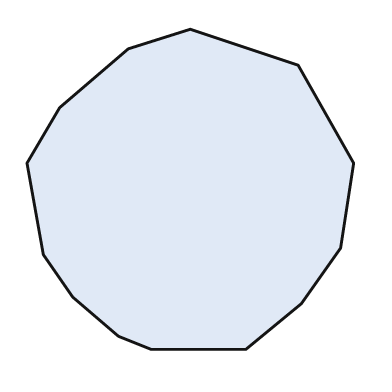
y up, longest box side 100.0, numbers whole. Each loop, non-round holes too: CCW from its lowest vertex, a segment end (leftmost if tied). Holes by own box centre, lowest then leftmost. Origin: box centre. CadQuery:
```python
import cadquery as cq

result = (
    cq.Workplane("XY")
    .moveTo(-12.0, -49.0)
    .lineTo(17.0, -49.0)
    .lineTo(34.0, -35.0)
    .lineTo(46.0, -18.0)
    .lineTo(50.0, 8.0)
    .lineTo(33.0, 38.0)
    .lineTo(0.0, 49.0)
    .lineTo(-19.0, 43.0)
    .lineTo(-40.0, 25.0)
    .lineTo(-50.0, 8.0)
    .lineTo(-45.0, -20.0)
    .lineTo(-36.0, -33.0)
    .lineTo(-22.0, -45.0)
    .close()
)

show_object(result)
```